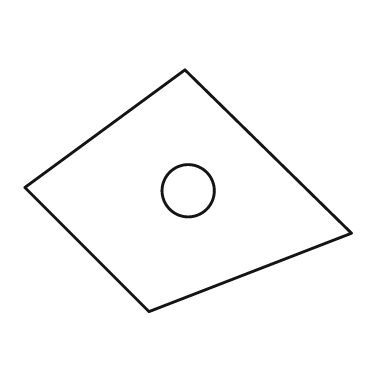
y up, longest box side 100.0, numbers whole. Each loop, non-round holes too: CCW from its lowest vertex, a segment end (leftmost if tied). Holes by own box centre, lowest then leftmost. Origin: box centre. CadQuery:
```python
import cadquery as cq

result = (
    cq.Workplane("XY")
    .moveTo(-12.0, -37.0)
    .lineTo(50.0, -13.0)
    .lineTo(-1.0, 37.0)
    .lineTo(-50.0, 1.0)
    .close()
    .moveTo(0.0, 0.0)
    .circle(8.0)
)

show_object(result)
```